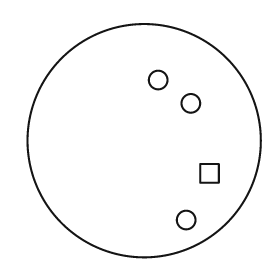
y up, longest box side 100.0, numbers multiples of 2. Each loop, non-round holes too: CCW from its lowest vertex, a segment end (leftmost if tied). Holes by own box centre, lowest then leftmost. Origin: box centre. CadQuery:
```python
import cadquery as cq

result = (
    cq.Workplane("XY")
    .moveTo(0.0, 0.0)
    .circle(50.0)
    .moveTo(18.0, -34.0)
    .circle(4.0)
    .moveTo(24.0, -18.0)
    .lineTo(32.0, -18.0)
    .lineTo(32.0, -10.0)
    .lineTo(24.0, -10.0)
    .close()
    .moveTo(20.0, 16.0)
    .circle(4.0)
    .moveTo(6.0, 26.0)
    .circle(4.0)
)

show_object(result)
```